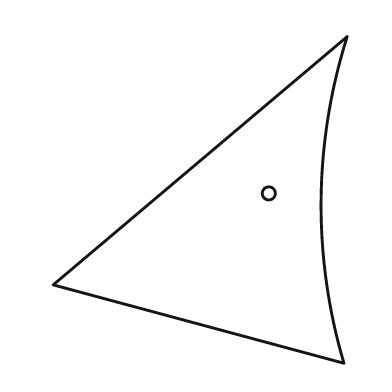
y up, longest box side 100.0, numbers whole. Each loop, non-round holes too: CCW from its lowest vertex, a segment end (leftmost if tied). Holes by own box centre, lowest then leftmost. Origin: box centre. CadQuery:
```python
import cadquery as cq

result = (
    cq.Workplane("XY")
    .moveTo(44.0, -50.0)
    .threePointArc((37.0, 0.0), (45.0, 50.0))
    .lineTo(-45.0, -26.0)
    .close()
    .moveTo(21.0, 2.0)
    .circle(2.0)
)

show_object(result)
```